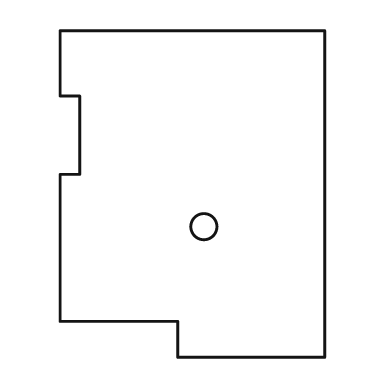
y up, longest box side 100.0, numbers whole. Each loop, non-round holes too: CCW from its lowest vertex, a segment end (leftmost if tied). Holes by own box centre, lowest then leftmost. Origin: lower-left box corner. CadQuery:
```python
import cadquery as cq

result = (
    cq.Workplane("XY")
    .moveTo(36.0, 0.0)
    .lineTo(81.0, 0.0)
    .lineTo(81.0, 100.0)
    .lineTo(0.0, 100.0)
    .lineTo(0.0, 80.0)
    .lineTo(6.0, 80.0)
    .lineTo(6.0, 56.0)
    .lineTo(0.0, 56.0)
    .lineTo(0.0, 11.0)
    .lineTo(36.0, 11.0)
    .close()
    .moveTo(44.0, 40.0)
    .circle(4.0)
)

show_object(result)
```